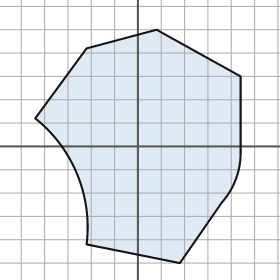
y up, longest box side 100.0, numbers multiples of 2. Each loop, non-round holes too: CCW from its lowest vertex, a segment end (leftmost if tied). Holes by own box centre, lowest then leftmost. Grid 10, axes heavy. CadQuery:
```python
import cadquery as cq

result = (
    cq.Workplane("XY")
    .moveTo(18.0, -50.0)
    .lineTo(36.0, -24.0)
    .threePointArc((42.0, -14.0), (44.0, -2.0))
    .lineTo(44.0, 30.0)
    .lineTo(8.0, 50.0)
    .lineTo(-22.0, 42.0)
    .lineTo(-44.0, 12.0)
    .threePointArc((-26.0, -12.0), (-22.0, -42.0))
    .close()
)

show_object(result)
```